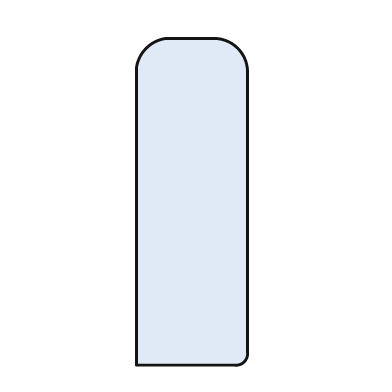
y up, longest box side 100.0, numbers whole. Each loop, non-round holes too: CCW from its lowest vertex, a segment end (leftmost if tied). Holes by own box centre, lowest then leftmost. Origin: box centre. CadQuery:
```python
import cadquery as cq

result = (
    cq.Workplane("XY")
    .moveTo(-17.0, -50.0)
    .lineTo(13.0, -50.0)
    .threePointArc((16.0, -49.0), (17.0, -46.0))
    .lineTo(17.0, 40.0)
    .threePointArc((14.0, 47.0), (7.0, 50.0))
    .lineTo(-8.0, 50.0)
    .threePointArc((-14.0, 47.0), (-17.0, 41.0))
    .close()
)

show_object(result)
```